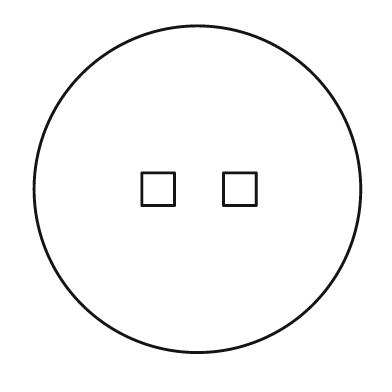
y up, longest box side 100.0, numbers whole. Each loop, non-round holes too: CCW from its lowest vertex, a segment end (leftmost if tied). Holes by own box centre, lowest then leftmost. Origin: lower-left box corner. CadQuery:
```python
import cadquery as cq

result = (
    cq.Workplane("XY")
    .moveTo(50.0, 50.0)
    .circle(50.0)
    .moveTo(33.0, 45.0)
    .lineTo(43.0, 45.0)
    .lineTo(43.0, 55.0)
    .lineTo(33.0, 55.0)
    .close()
    .moveTo(58.0, 45.0)
    .lineTo(68.0, 45.0)
    .lineTo(68.0, 55.0)
    .lineTo(58.0, 55.0)
    .close()
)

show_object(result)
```